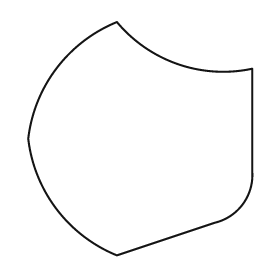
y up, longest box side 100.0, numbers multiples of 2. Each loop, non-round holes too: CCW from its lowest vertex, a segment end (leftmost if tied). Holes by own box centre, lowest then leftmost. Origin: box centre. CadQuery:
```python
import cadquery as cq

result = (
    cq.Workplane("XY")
    .moveTo(-10.0, -50.0)
    .lineTo(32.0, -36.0)
    .threePointArc((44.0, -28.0), (48.0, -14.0))
    .lineTo(48.0, 30.0)
    .threePointArc((16.0, 32.0), (-10.0, 50.0))
    .threePointArc((-36.0, 30.0), (-48.0, 0.0))
    .threePointArc((-36.0, -30.0), (-10.0, -50.0))
    .close()
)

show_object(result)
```